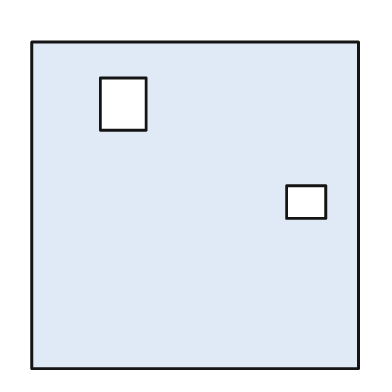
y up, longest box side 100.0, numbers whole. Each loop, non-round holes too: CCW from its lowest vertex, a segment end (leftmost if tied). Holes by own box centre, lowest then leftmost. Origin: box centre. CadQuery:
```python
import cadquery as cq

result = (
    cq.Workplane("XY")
    .moveTo(-50.0, -50.0)
    .lineTo(50.0, -50.0)
    .lineTo(50.0, 50.0)
    .lineTo(-50.0, 50.0)
    .close()
    .moveTo(28.0, -4.0)
    .lineTo(40.0, -4.0)
    .lineTo(40.0, 6.0)
    .lineTo(28.0, 6.0)
    .close()
    .moveTo(-29.0, 23.0)
    .lineTo(-15.0, 23.0)
    .lineTo(-15.0, 39.0)
    .lineTo(-29.0, 39.0)
    .close()
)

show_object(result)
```